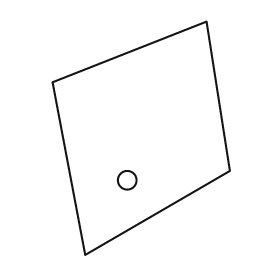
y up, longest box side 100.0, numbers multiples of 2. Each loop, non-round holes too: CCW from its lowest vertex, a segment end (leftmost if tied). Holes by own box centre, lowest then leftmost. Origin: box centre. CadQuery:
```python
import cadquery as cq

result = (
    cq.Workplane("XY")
    .moveTo(-24.0, -50.0)
    .lineTo(38.0, -14.0)
    .lineTo(28.0, 50.0)
    .lineTo(-38.0, 24.0)
    .close()
    .moveTo(-6.0, -18.0)
    .circle(4.0)
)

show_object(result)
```